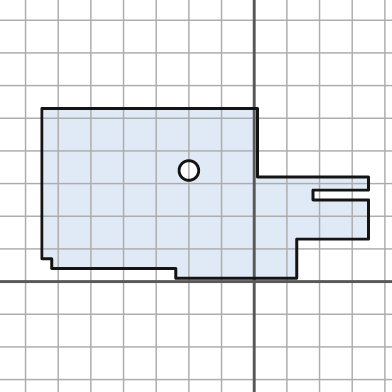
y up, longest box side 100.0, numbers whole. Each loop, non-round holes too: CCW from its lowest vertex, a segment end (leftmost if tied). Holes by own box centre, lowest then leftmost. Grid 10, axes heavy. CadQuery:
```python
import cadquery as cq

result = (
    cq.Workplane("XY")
    .moveTo(-24.0, 1.0)
    .lineTo(13.0, 1.0)
    .lineTo(13.0, 13.0)
    .lineTo(35.0, 13.0)
    .lineTo(35.0, 25.0)
    .lineTo(18.0, 25.0)
    .lineTo(18.0, 28.0)
    .lineTo(35.0, 28.0)
    .lineTo(35.0, 32.0)
    .lineTo(1.0, 32.0)
    .lineTo(1.0, 53.0)
    .lineTo(-65.0, 53.0)
    .lineTo(-65.0, 7.0)
    .lineTo(-62.0, 7.0)
    .lineTo(-62.0, 4.0)
    .lineTo(-24.0, 4.0)
    .close()
    .moveTo(-20.0, 34.0)
    .circle(3.0)
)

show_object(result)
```